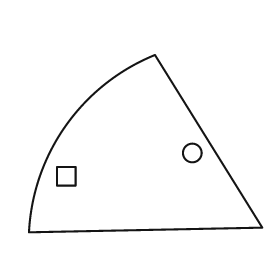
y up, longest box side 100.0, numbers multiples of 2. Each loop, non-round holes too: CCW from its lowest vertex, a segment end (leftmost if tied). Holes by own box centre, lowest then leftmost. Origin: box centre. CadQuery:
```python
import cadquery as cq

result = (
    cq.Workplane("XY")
    .moveTo(-50.0, -38.0)
    .lineTo(50.0, -36.0)
    .lineTo(4.0, 38.0)
    .threePointArc((-34.0, 8.0), (-50.0, -38.0))
    .close()
    .moveTo(-38.0, -18.0)
    .lineTo(-30.0, -18.0)
    .lineTo(-30.0, -10.0)
    .lineTo(-38.0, -10.0)
    .close()
    .moveTo(20.0, -4.0)
    .circle(4.0)
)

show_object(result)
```